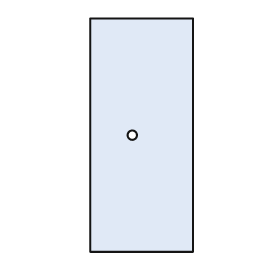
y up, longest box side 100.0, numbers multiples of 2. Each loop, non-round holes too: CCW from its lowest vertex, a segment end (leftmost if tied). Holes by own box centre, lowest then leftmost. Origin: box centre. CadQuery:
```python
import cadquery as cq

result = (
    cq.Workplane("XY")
    .moveTo(-22.0, -50.0)
    .lineTo(22.0, -50.0)
    .lineTo(22.0, 50.0)
    .lineTo(-22.0, 50.0)
    .close()
    .moveTo(-4.0, 0.0)
    .circle(2.0)
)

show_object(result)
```